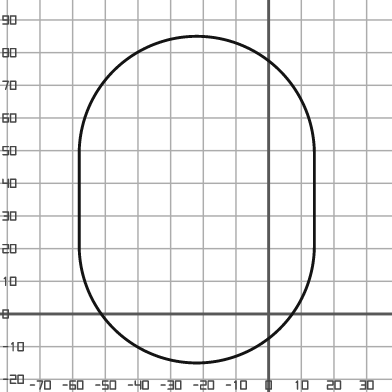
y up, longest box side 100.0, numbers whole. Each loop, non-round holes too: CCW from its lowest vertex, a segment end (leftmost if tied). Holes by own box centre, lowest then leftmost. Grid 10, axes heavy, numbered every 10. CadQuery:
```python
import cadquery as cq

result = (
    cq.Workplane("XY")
    .moveTo(-58.0, 21.0)
    .threePointArc((-22.0, -15.0), (14.0, 21.0))
    .lineTo(14.0, 49.0)
    .threePointArc((-22.0, 85.0), (-58.0, 49.0))
    .close()
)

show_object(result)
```